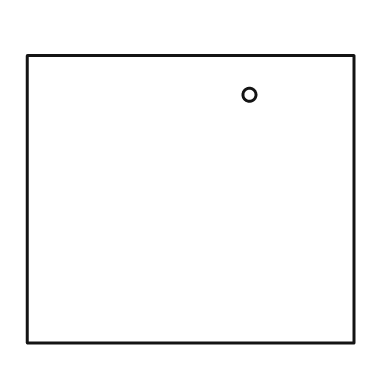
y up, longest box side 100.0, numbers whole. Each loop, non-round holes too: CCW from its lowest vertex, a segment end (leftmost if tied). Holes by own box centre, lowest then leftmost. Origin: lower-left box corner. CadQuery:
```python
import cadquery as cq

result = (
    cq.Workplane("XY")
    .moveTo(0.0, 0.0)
    .lineTo(100.0, 0.0)
    .lineTo(100.0, 88.0)
    .lineTo(0.0, 88.0)
    .close()
    .moveTo(68.0, 76.0)
    .circle(2.0)
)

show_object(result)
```